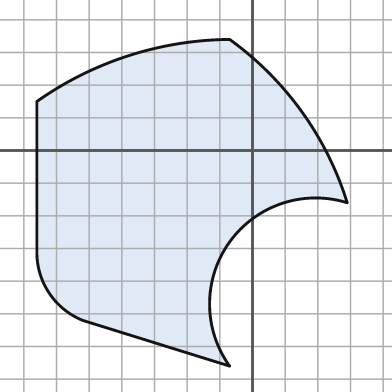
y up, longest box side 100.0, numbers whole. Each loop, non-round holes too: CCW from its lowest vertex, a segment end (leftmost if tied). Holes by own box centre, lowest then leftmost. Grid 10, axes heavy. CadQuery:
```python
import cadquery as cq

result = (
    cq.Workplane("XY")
    .moveTo(-7.0, -66.0)
    .threePointArc((-7.0, -28.0), (29.0, -16.0))
    .threePointArc((15.0, 12.0), (-7.0, 34.0))
    .threePointArc((-38.0, 29.0), (-66.0, 15.0))
    .lineTo(-66.0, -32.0)
    .threePointArc((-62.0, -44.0), (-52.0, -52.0))
    .close()
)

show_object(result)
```